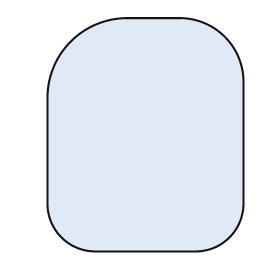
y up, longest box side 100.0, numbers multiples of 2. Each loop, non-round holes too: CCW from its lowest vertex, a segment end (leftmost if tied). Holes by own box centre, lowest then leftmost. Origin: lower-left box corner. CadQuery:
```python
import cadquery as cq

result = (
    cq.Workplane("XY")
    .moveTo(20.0, 0.0)
    .lineTo(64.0, 0.0)
    .threePointArc((78.0, 6.0), (84.0, 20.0))
    .lineTo(84.0, 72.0)
    .threePointArc((76.0, 92.0), (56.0, 100.0))
    .lineTo(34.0, 100.0)
    .threePointArc((10.0, 90.0), (0.0, 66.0))
    .lineTo(0.0, 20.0)
    .threePointArc((6.0, 6.0), (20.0, 0.0))
    .close()
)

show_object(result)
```